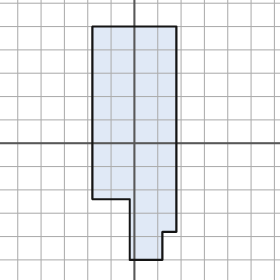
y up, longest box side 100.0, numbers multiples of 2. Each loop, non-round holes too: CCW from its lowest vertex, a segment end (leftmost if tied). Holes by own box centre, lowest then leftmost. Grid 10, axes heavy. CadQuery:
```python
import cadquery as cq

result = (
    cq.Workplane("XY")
    .moveTo(-2.0, -50.0)
    .lineTo(12.0, -50.0)
    .lineTo(12.0, -38.0)
    .lineTo(18.0, -38.0)
    .lineTo(18.0, 50.0)
    .lineTo(-18.0, 50.0)
    .lineTo(-18.0, -24.0)
    .lineTo(-2.0, -24.0)
    .close()
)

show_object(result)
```